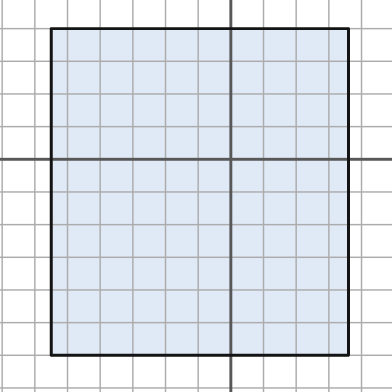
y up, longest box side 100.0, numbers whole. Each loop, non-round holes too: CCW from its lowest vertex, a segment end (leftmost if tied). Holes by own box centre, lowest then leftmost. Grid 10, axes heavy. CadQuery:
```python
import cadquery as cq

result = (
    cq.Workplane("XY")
    .moveTo(-55.0, -60.0)
    .lineTo(36.0, -60.0)
    .lineTo(36.0, 40.0)
    .lineTo(-55.0, 40.0)
    .close()
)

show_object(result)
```